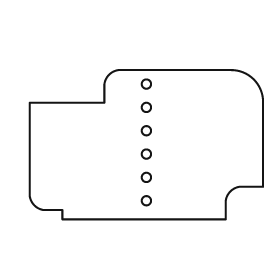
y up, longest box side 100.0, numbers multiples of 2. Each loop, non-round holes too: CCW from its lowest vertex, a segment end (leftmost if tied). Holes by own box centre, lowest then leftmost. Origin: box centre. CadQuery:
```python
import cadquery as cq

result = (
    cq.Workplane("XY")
    .moveTo(-36.0, -32.0)
    .lineTo(34.0, -32.0)
    .lineTo(34.0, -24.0)
    .threePointArc((36.0, -20.0), (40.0, -18.0))
    .lineTo(50.0, -18.0)
    .lineTo(50.0, 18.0)
    .threePointArc((46.0, 28.0), (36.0, 32.0))
    .lineTo(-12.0, 32.0)
    .threePointArc((-16.0, 30.0), (-18.0, 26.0))
    .lineTo(-18.0, 18.0)
    .lineTo(-50.0, 18.0)
    .lineTo(-50.0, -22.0)
    .threePointArc((-48.0, -26.0), (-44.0, -28.0))
    .lineTo(-36.0, -28.0)
    .close()
    .moveTo(0.0, -24.0)
    .circle(2.0)
    .moveTo(0.0, -14.0)
    .circle(2.0)
    .moveTo(0.0, -4.0)
    .circle(2.0)
    .moveTo(0.0, 6.0)
    .circle(2.0)
    .moveTo(0.0, 16.0)
    .circle(2.0)
    .moveTo(0.0, 26.0)
    .circle(2.0)
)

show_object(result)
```